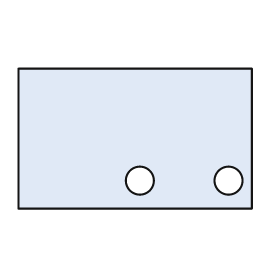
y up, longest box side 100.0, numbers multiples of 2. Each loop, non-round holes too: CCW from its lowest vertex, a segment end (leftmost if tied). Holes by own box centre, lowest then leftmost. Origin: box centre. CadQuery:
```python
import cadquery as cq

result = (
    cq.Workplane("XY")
    .moveTo(-50.0, -30.0)
    .lineTo(50.0, -30.0)
    .lineTo(50.0, 30.0)
    .lineTo(-50.0, 30.0)
    .close()
    .moveTo(2.0, -18.0)
    .circle(6.0)
    .moveTo(40.0, -18.0)
    .circle(6.0)
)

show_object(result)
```